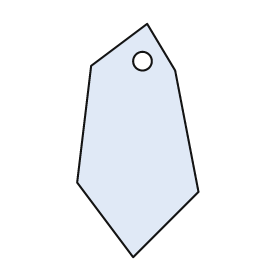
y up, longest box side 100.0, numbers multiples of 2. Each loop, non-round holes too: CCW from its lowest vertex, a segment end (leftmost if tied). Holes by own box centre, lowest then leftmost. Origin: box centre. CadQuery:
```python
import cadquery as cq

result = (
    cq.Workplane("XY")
    .moveTo(-2.0, -50.0)
    .lineTo(26.0, -22.0)
    .lineTo(16.0, 30.0)
    .lineTo(4.0, 50.0)
    .lineTo(-20.0, 32.0)
    .lineTo(-26.0, -18.0)
    .close()
    .moveTo(2.0, 34.0)
    .circle(4.0)
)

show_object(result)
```